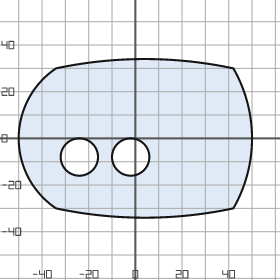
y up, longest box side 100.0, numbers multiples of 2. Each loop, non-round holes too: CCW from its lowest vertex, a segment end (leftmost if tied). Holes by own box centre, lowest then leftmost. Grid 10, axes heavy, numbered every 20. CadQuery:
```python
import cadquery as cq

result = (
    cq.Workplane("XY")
    .moveTo(-34.0, -30.0)
    .threePointArc((4.0, -34.0), (42.0, -30.0))
    .threePointArc((50.0, 0.0), (42.0, 30.0))
    .threePointArc((4.0, 34.0), (-34.0, 30.0))
    .threePointArc((-50.0, 0.0), (-34.0, -30.0))
    .close()
    .moveTo(-24.0, -8.0)
    .circle(8.0)
    .moveTo(-2.0, -8.0)
    .circle(8.0)
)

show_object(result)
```